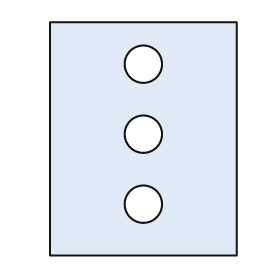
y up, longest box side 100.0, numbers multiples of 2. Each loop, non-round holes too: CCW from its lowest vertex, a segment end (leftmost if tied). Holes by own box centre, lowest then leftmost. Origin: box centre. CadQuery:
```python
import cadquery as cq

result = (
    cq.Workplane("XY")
    .moveTo(-40.0, -50.0)
    .lineTo(40.0, -50.0)
    .lineTo(40.0, 50.0)
    .lineTo(-40.0, 50.0)
    .close()
    .moveTo(0.0, -28.0)
    .circle(8.0)
    .moveTo(0.0, 2.0)
    .circle(8.0)
    .moveTo(0.0, 32.0)
    .circle(8.0)
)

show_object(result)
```